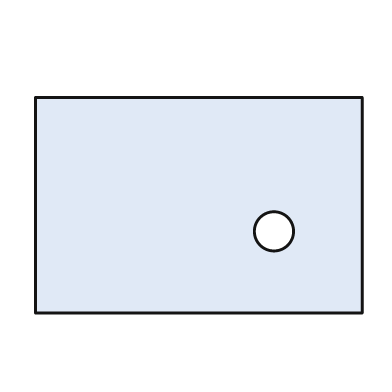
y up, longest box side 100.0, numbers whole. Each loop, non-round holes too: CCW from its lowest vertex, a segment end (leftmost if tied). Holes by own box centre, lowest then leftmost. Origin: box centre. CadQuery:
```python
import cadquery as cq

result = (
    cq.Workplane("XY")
    .moveTo(-50.0, -33.0)
    .lineTo(50.0, -33.0)
    .lineTo(50.0, 33.0)
    .lineTo(-50.0, 33.0)
    .close()
    .moveTo(23.0, -8.0)
    .circle(6.0)
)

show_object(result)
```